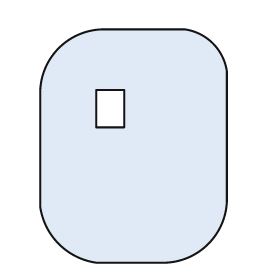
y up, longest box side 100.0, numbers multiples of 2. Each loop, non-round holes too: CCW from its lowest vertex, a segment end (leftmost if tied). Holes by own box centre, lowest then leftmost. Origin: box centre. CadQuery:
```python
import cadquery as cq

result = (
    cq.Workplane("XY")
    .moveTo(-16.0, -50.0)
    .lineTo(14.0, -50.0)
    .threePointArc((32.0, -42.0), (40.0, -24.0))
    .lineTo(40.0, 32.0)
    .threePointArc((34.0, 44.0), (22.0, 50.0))
    .lineTo(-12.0, 50.0)
    .threePointArc((-32.0, 42.0), (-40.0, 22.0))
    .lineTo(-40.0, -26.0)
    .threePointArc((-32.0, -42.0), (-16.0, -50.0))
    .close()
    .moveTo(-16.0, 8.0)
    .lineTo(-4.0, 8.0)
    .lineTo(-4.0, 24.0)
    .lineTo(-16.0, 24.0)
    .close()
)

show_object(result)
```